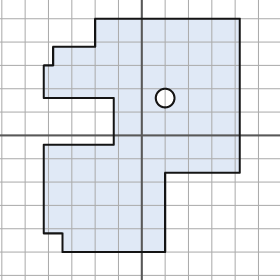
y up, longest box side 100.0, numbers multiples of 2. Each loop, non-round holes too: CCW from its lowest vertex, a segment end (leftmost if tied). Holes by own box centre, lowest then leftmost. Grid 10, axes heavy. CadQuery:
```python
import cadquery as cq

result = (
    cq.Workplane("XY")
    .moveTo(-34.0, -50.0)
    .lineTo(10.0, -50.0)
    .lineTo(10.0, -16.0)
    .lineTo(42.0, -16.0)
    .lineTo(42.0, 50.0)
    .lineTo(-20.0, 50.0)
    .lineTo(-20.0, 38.0)
    .lineTo(-38.0, 38.0)
    .lineTo(-38.0, 30.0)
    .lineTo(-42.0, 30.0)
    .lineTo(-42.0, 16.0)
    .lineTo(-12.0, 16.0)
    .lineTo(-12.0, -4.0)
    .lineTo(-42.0, -4.0)
    .lineTo(-42.0, -42.0)
    .lineTo(-34.0, -42.0)
    .close()
    .moveTo(10.0, 16.0)
    .circle(4.0)
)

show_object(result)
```